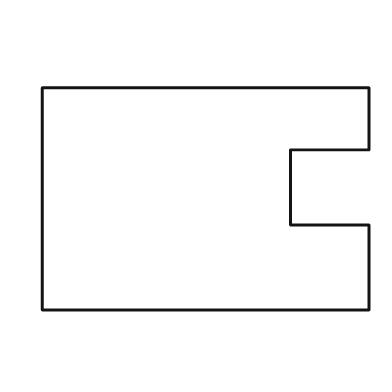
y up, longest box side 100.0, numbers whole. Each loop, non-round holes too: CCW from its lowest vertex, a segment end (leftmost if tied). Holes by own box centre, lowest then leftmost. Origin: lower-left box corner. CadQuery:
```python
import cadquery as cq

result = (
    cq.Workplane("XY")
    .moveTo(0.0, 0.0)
    .lineTo(100.0, 0.0)
    .lineTo(100.0, 26.0)
    .lineTo(76.0, 26.0)
    .lineTo(76.0, 49.0)
    .lineTo(100.0, 49.0)
    .lineTo(100.0, 68.0)
    .lineTo(0.0, 68.0)
    .close()
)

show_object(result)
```